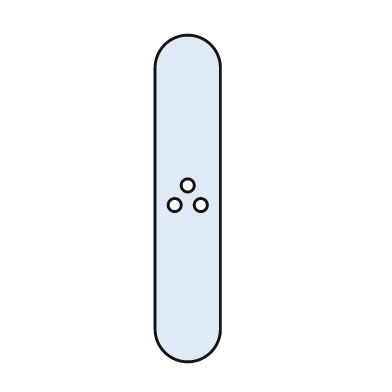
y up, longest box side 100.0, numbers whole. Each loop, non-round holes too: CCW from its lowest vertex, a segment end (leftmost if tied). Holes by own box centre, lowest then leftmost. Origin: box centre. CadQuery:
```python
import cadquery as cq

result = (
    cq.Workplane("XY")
    .moveTo(-10.0, -40.0)
    .threePointArc((0.0, -50.0), (10.0, -40.0))
    .lineTo(10.0, 40.0)
    .threePointArc((0.0, 50.0), (-10.0, 40.0))
    .close()
    .moveTo(-4.0, -2.0)
    .circle(2.0)
    .moveTo(4.0, -2.0)
    .circle(2.0)
    .moveTo(0.0, 4.0)
    .circle(2.0)
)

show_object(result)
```